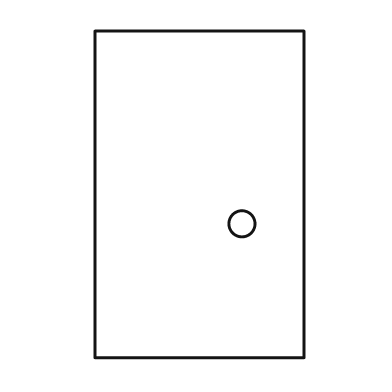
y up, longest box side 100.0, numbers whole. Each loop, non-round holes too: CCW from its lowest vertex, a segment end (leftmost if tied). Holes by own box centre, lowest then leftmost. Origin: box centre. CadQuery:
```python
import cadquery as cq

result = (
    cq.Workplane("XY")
    .moveTo(-32.0, -50.0)
    .lineTo(32.0, -50.0)
    .lineTo(32.0, 50.0)
    .lineTo(-32.0, 50.0)
    .close()
    .moveTo(13.0, -9.0)
    .circle(4.0)
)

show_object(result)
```